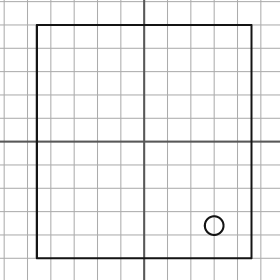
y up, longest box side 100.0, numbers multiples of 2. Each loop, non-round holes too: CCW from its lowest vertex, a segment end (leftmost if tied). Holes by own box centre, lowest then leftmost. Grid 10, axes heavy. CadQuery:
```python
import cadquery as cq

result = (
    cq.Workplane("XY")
    .moveTo(-46.0, -50.0)
    .lineTo(46.0, -50.0)
    .lineTo(46.0, 50.0)
    .lineTo(-46.0, 50.0)
    .close()
    .moveTo(30.0, -36.0)
    .circle(4.0)
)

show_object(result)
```